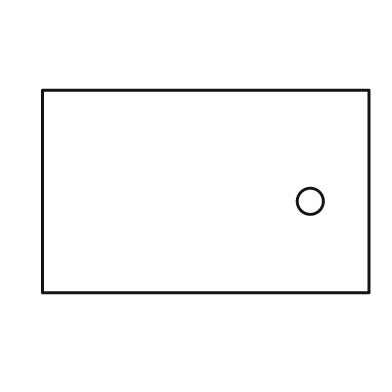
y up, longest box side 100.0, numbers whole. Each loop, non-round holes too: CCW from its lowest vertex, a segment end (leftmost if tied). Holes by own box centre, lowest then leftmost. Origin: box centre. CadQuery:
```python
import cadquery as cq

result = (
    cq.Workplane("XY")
    .moveTo(-50.0, -31.0)
    .lineTo(50.0, -31.0)
    .lineTo(50.0, 31.0)
    .lineTo(-50.0, 31.0)
    .close()
    .moveTo(32.0, -3.0)
    .circle(4.0)
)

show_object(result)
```